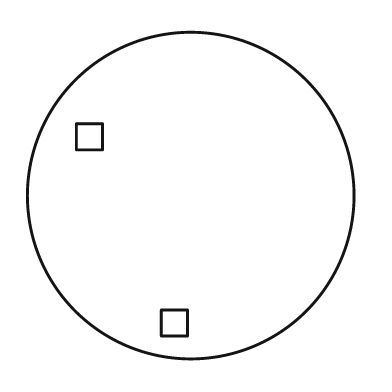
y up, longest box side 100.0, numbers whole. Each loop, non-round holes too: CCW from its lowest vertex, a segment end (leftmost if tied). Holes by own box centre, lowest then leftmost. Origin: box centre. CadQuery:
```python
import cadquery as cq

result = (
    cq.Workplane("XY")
    .moveTo(0.0, 0.0)
    .circle(50.0)
    .moveTo(-9.0, -43.0)
    .lineTo(-1.0, -43.0)
    .lineTo(-1.0, -35.0)
    .lineTo(-9.0, -35.0)
    .close()
    .moveTo(-35.0, 14.0)
    .lineTo(-27.0, 14.0)
    .lineTo(-27.0, 22.0)
    .lineTo(-35.0, 22.0)
    .close()
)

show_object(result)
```